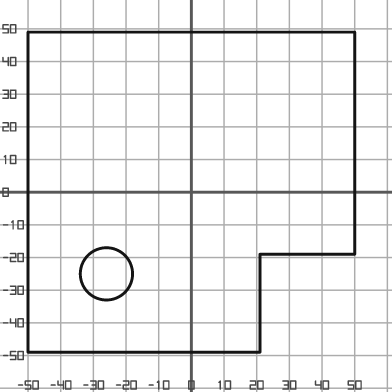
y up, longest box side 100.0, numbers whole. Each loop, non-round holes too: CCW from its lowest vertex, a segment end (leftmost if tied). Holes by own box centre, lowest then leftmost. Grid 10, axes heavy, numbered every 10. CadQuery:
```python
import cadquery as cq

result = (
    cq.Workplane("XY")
    .moveTo(-50.0, -49.0)
    .lineTo(21.0, -49.0)
    .lineTo(21.0, -19.0)
    .lineTo(50.0, -19.0)
    .lineTo(50.0, 49.0)
    .lineTo(-50.0, 49.0)
    .close()
    .moveTo(-26.0, -25.0)
    .circle(8.0)
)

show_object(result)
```